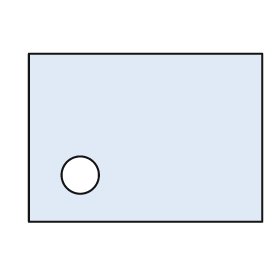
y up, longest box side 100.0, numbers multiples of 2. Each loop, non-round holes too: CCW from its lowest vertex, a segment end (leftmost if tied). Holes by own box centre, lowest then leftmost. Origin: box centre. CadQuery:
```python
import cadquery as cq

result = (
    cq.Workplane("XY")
    .moveTo(-50.0, -36.0)
    .lineTo(50.0, -36.0)
    .lineTo(50.0, 36.0)
    .lineTo(-50.0, 36.0)
    .close()
    .moveTo(-28.0, -16.0)
    .circle(8.0)
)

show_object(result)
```